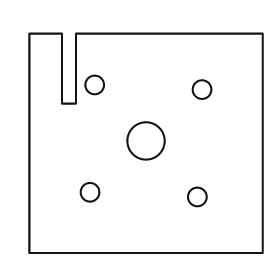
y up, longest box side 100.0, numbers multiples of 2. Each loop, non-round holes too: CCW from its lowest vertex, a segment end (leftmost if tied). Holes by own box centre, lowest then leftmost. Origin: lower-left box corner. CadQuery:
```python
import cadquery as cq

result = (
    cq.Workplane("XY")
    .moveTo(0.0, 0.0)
    .lineTo(100.0, 0.0)
    .lineTo(100.0, 94.0)
    .lineTo(20.0, 94.0)
    .lineTo(20.0, 64.0)
    .lineTo(14.0, 64.0)
    .lineTo(14.0, 94.0)
    .lineTo(0.0, 94.0)
    .close()
    .moveTo(72.0, 24.0)
    .circle(4.0)
    .moveTo(26.0, 26.0)
    .circle(4.0)
    .moveTo(50.0, 48.0)
    .circle(8.0)
    .moveTo(74.0, 70.0)
    .circle(4.0)
    .moveTo(28.0, 72.0)
    .circle(4.0)
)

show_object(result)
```